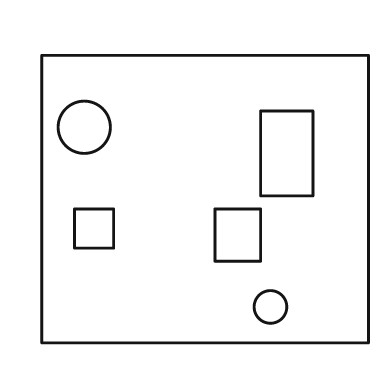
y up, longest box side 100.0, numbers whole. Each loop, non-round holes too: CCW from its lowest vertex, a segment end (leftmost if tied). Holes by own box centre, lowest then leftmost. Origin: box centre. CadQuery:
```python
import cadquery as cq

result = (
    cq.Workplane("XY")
    .moveTo(-50.0, -44.0)
    .lineTo(50.0, -44.0)
    .lineTo(50.0, 44.0)
    .lineTo(-50.0, 44.0)
    .close()
    .moveTo(20.0, -33.0)
    .circle(5.0)
    .moveTo(3.0, -19.0)
    .lineTo(17.0, -19.0)
    .lineTo(17.0, -3.0)
    .lineTo(3.0, -3.0)
    .close()
    .moveTo(-40.0, -15.0)
    .lineTo(-28.0, -15.0)
    .lineTo(-28.0, -3.0)
    .lineTo(-40.0, -3.0)
    .close()
    .moveTo(17.0, 1.0)
    .lineTo(33.0, 1.0)
    .lineTo(33.0, 27.0)
    .lineTo(17.0, 27.0)
    .close()
    .moveTo(-37.0, 22.0)
    .circle(8.0)
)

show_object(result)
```